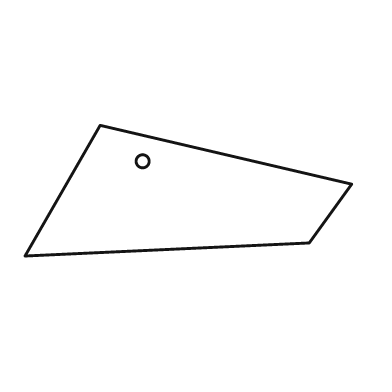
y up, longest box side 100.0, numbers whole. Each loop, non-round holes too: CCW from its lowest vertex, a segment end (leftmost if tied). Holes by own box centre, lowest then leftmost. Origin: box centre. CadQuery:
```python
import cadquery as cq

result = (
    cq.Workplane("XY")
    .moveTo(-50.0, -20.0)
    .lineTo(37.0, -16.0)
    .lineTo(50.0, 2.0)
    .lineTo(-27.0, 20.0)
    .close()
    .moveTo(-14.0, 9.0)
    .circle(2.0)
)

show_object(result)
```